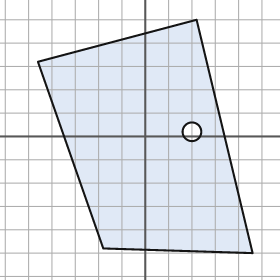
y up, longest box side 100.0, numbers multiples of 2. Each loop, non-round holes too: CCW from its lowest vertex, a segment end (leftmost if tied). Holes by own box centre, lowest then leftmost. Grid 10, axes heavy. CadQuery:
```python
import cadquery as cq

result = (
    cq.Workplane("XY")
    .moveTo(46.0, -50.0)
    .lineTo(22.0, 50.0)
    .lineTo(-46.0, 32.0)
    .lineTo(-18.0, -48.0)
    .close()
    .moveTo(20.0, 2.0)
    .circle(4.0)
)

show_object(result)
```